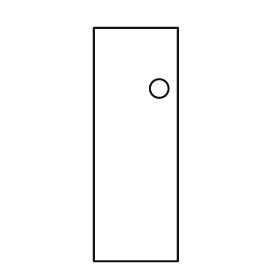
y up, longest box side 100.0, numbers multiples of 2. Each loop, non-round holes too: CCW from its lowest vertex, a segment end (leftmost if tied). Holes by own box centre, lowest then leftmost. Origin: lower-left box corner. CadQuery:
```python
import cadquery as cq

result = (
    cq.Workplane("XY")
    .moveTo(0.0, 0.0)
    .lineTo(36.0, 0.0)
    .lineTo(36.0, 100.0)
    .lineTo(0.0, 100.0)
    .close()
    .moveTo(28.0, 74.0)
    .circle(4.0)
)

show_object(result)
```